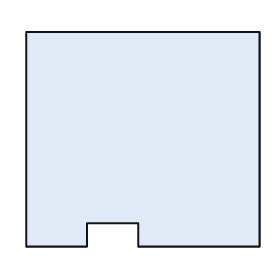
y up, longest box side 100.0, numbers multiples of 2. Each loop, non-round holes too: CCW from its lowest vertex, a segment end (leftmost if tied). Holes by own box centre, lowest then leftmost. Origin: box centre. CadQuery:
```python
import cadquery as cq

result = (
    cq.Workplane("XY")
    .moveTo(-50.0, -46.0)
    .lineTo(-24.0, -46.0)
    .lineTo(-24.0, -36.0)
    .lineTo(-2.0, -36.0)
    .lineTo(-2.0, -46.0)
    .lineTo(50.0, -46.0)
    .lineTo(50.0, 46.0)
    .lineTo(-50.0, 46.0)
    .close()
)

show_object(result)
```